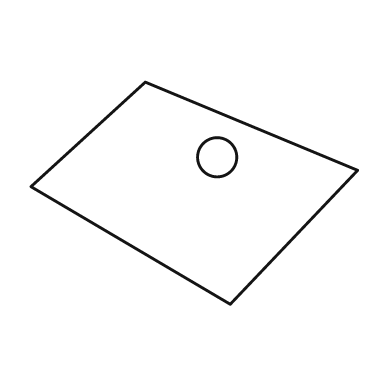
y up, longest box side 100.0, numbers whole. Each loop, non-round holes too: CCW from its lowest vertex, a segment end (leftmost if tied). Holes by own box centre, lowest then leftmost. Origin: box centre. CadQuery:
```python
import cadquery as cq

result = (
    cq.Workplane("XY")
    .moveTo(11.0, -34.0)
    .lineTo(50.0, 7.0)
    .lineTo(-15.0, 34.0)
    .lineTo(-50.0, 2.0)
    .close()
    .moveTo(7.0, 11.0)
    .circle(6.0)
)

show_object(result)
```